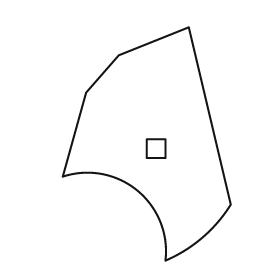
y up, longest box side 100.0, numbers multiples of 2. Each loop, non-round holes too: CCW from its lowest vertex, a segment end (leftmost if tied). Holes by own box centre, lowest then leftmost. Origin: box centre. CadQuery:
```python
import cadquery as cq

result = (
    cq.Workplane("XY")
    .moveTo(8.0, -50.0)
    .threePointArc((24.0, -40.0), (36.0, -26.0))
    .lineTo(18.0, 50.0)
    .lineTo(-12.0, 38.0)
    .lineTo(-26.0, 22.0)
    .lineTo(-36.0, -14.0)
    .threePointArc((-4.0, -20.0), (8.0, -50.0))
    .close()
    .moveTo(0.0, -6.0)
    .lineTo(8.0, -6.0)
    .lineTo(8.0, 2.0)
    .lineTo(0.0, 2.0)
    .close()
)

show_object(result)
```